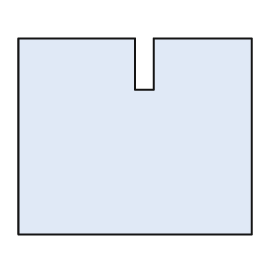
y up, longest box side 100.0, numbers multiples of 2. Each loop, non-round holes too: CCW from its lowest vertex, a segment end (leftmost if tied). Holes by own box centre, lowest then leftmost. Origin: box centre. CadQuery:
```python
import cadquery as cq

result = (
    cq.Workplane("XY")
    .moveTo(-50.0, -42.0)
    .lineTo(50.0, -42.0)
    .lineTo(50.0, 42.0)
    .lineTo(8.0, 42.0)
    .lineTo(8.0, 20.0)
    .lineTo(0.0, 20.0)
    .lineTo(0.0, 42.0)
    .lineTo(-50.0, 42.0)
    .close()
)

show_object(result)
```